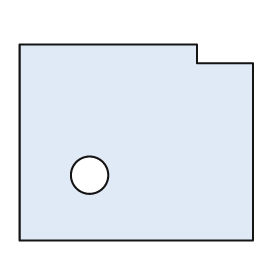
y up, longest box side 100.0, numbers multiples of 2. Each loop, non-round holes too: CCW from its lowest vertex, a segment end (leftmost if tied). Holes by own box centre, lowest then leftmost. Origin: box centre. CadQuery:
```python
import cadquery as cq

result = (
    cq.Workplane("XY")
    .moveTo(-50.0, -42.0)
    .lineTo(50.0, -42.0)
    .lineTo(50.0, 34.0)
    .lineTo(26.0, 34.0)
    .lineTo(26.0, 42.0)
    .lineTo(-50.0, 42.0)
    .close()
    .moveTo(-20.0, -14.0)
    .circle(8.0)
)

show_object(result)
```